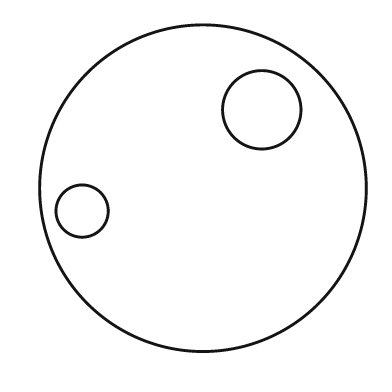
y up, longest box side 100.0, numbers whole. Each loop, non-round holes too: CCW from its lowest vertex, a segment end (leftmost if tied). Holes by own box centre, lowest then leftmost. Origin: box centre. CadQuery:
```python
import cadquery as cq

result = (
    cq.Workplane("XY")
    .moveTo(0.0, 0.0)
    .circle(50.0)
    .moveTo(-37.0, -7.0)
    .circle(8.0)
    .moveTo(18.0, 24.0)
    .circle(12.0)
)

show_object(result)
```